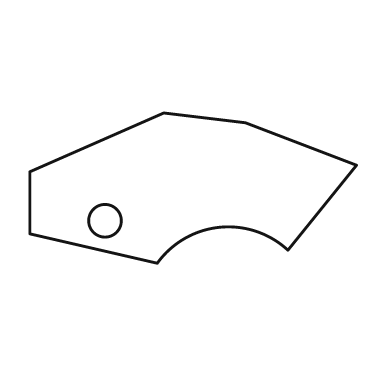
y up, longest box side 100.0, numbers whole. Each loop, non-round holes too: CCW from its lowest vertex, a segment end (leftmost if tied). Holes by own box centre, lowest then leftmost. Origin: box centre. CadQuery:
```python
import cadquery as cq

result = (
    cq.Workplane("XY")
    .moveTo(-11.0, -23.0)
    .threePointArc((8.0, -12.0), (29.0, -19.0))
    .lineTo(50.0, 7.0)
    .lineTo(16.0, 20.0)
    .lineTo(-9.0, 23.0)
    .lineTo(-50.0, 5.0)
    .lineTo(-50.0, -14.0)
    .close()
    .moveTo(-27.0, -10.0)
    .circle(5.0)
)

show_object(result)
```